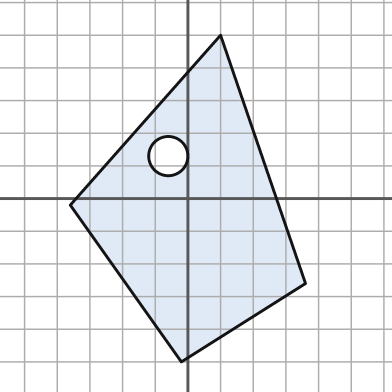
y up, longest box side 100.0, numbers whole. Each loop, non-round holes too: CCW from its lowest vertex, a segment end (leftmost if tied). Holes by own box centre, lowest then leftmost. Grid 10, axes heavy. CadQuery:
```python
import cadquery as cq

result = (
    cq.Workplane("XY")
    .moveTo(-2.0, -50.0)
    .lineTo(36.0, -26.0)
    .lineTo(10.0, 50.0)
    .lineTo(-36.0, -2.0)
    .close()
    .moveTo(-6.0, 13.0)
    .circle(6.0)
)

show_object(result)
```